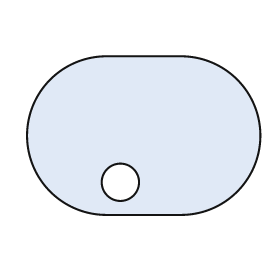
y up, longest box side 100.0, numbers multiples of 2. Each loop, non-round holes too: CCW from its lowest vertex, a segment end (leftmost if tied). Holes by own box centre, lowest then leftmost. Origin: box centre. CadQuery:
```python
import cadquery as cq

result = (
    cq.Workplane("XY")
    .moveTo(-16.0, -34.0)
    .lineTo(16.0, -34.0)
    .threePointArc((50.0, 0.0), (16.0, 34.0))
    .lineTo(-16.0, 34.0)
    .threePointArc((-50.0, 0.0), (-16.0, -34.0))
    .close()
    .moveTo(-10.0, -20.0)
    .circle(8.0)
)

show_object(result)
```